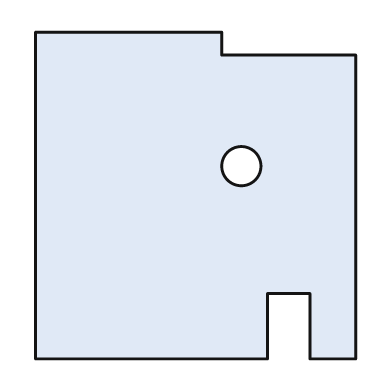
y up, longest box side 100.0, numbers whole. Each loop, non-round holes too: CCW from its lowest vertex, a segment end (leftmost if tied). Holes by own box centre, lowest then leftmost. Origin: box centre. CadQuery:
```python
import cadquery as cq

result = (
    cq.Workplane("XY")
    .moveTo(-49.0, -50.0)
    .lineTo(22.0, -50.0)
    .lineTo(22.0, -30.0)
    .lineTo(35.0, -30.0)
    .lineTo(35.0, -50.0)
    .lineTo(49.0, -50.0)
    .lineTo(49.0, 43.0)
    .lineTo(8.0, 43.0)
    .lineTo(8.0, 50.0)
    .lineTo(-49.0, 50.0)
    .close()
    .moveTo(14.0, 9.0)
    .circle(6.0)
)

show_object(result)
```